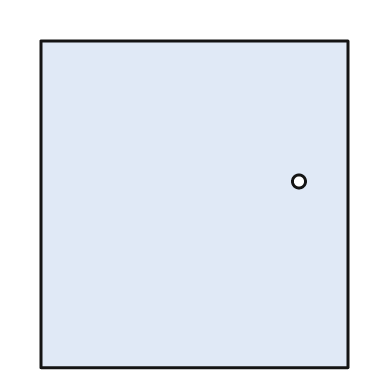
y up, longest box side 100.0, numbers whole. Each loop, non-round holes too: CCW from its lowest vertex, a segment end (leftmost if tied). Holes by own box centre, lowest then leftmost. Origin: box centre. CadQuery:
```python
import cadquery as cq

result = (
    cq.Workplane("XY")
    .moveTo(-47.0, -50.0)
    .lineTo(47.0, -50.0)
    .lineTo(47.0, 50.0)
    .lineTo(-47.0, 50.0)
    .close()
    .moveTo(32.0, 7.0)
    .circle(2.0)
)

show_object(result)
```